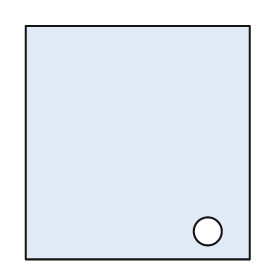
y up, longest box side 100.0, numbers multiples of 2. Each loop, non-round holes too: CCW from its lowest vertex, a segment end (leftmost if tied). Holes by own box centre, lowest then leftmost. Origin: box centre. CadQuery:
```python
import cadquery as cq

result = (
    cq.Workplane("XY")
    .moveTo(-48.0, -50.0)
    .lineTo(48.0, -50.0)
    .lineTo(48.0, 50.0)
    .lineTo(-48.0, 50.0)
    .close()
    .moveTo(30.0, -38.0)
    .circle(6.0)
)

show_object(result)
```